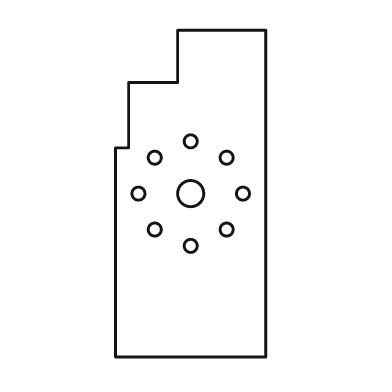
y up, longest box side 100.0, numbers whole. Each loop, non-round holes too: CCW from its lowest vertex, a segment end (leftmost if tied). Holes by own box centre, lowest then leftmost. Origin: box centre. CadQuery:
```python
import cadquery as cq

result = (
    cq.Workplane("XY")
    .moveTo(-23.0, -50.0)
    .lineTo(23.0, -50.0)
    .lineTo(23.0, 50.0)
    .lineTo(-4.0, 50.0)
    .lineTo(-4.0, 34.0)
    .lineTo(-19.0, 34.0)
    .lineTo(-19.0, 14.0)
    .lineTo(-23.0, 14.0)
    .close()
    .moveTo(0.0, -16.0)
    .circle(2.0)
    .moveTo(-11.0, -11.0)
    .circle(2.0)
    .moveTo(11.0, -11.0)
    .circle(2.0)
    .moveTo(-16.0, 0.0)
    .circle(2.0)
    .moveTo(0.0, 0.0)
    .circle(4.0)
    .moveTo(16.0, 0.0)
    .circle(2.0)
    .moveTo(-11.0, 11.0)
    .circle(2.0)
    .moveTo(11.0, 11.0)
    .circle(2.0)
    .moveTo(0.0, 16.0)
    .circle(2.0)
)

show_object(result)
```